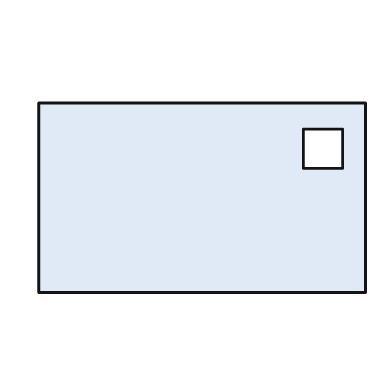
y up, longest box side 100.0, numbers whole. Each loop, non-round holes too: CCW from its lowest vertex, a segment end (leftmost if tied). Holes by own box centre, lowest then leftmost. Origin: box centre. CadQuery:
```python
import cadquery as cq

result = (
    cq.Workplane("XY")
    .moveTo(-50.0, -29.0)
    .lineTo(50.0, -29.0)
    .lineTo(50.0, 29.0)
    .lineTo(-50.0, 29.0)
    .close()
    .moveTo(31.0, 9.0)
    .lineTo(43.0, 9.0)
    .lineTo(43.0, 21.0)
    .lineTo(31.0, 21.0)
    .close()
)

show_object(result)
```